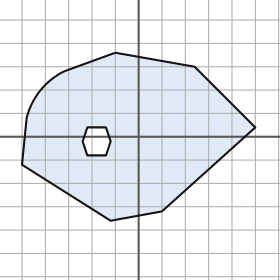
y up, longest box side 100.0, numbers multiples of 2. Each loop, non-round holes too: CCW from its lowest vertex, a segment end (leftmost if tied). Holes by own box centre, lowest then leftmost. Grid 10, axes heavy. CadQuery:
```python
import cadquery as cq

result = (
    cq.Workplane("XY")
    .moveTo(-12.0, -36.0)
    .lineTo(10.0, -32.0)
    .lineTo(50.0, 4.0)
    .lineTo(24.0, 30.0)
    .lineTo(-10.0, 36.0)
    .lineTo(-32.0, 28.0)
    .threePointArc((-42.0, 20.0), (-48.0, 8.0))
    .lineTo(-50.0, -12.0)
    .close()
    .moveTo(-22.0, -8.0)
    .lineTo(-14.0, -8.0)
    .lineTo(-12.0, -2.0)
    .lineTo(-14.0, 4.0)
    .lineTo(-22.0, 4.0)
    .lineTo(-24.0, -2.0)
    .close()
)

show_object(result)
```